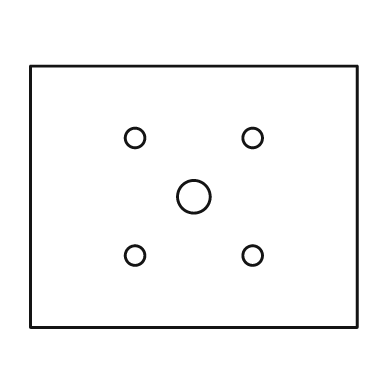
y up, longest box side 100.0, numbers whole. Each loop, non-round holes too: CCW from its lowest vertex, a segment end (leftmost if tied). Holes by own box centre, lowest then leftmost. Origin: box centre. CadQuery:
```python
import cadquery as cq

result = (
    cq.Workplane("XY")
    .moveTo(-50.0, -40.0)
    .lineTo(50.0, -40.0)
    .lineTo(50.0, 40.0)
    .lineTo(-50.0, 40.0)
    .close()
    .moveTo(-18.0, -18.0)
    .circle(3.0)
    .moveTo(18.0, -18.0)
    .circle(3.0)
    .moveTo(0.0, 0.0)
    .circle(5.0)
    .moveTo(-18.0, 18.0)
    .circle(3.0)
    .moveTo(18.0, 18.0)
    .circle(3.0)
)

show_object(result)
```